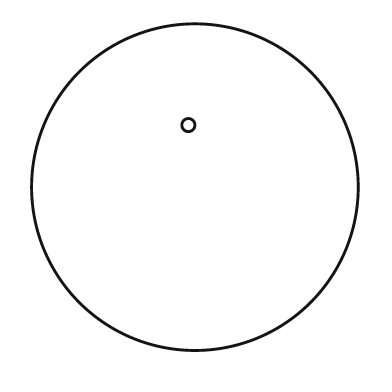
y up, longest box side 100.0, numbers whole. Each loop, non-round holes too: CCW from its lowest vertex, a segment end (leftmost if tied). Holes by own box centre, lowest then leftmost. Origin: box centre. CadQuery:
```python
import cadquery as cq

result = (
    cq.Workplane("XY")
    .moveTo(0.0, 0.0)
    .circle(50.0)
    .moveTo(-2.0, 19.0)
    .circle(2.0)
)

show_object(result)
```